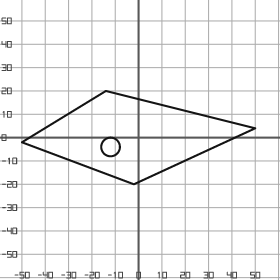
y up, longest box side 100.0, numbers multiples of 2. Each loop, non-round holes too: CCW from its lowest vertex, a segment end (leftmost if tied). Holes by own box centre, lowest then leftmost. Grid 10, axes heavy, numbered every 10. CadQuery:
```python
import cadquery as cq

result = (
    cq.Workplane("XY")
    .moveTo(-2.0, -20.0)
    .lineTo(50.0, 4.0)
    .lineTo(-14.0, 20.0)
    .lineTo(-50.0, -2.0)
    .close()
    .moveTo(-12.0, -4.0)
    .circle(4.0)
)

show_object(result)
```